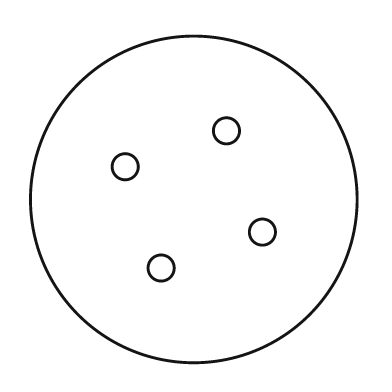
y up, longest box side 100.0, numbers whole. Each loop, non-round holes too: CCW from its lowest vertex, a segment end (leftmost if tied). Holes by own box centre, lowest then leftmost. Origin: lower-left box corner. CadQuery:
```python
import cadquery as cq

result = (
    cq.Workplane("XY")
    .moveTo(50.0, 50.0)
    .circle(50.0)
    .moveTo(40.0, 29.0)
    .circle(4.0)
    .moveTo(71.0, 40.0)
    .circle(4.0)
    .moveTo(29.0, 60.0)
    .circle(4.0)
    .moveTo(60.0, 71.0)
    .circle(4.0)
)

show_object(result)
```